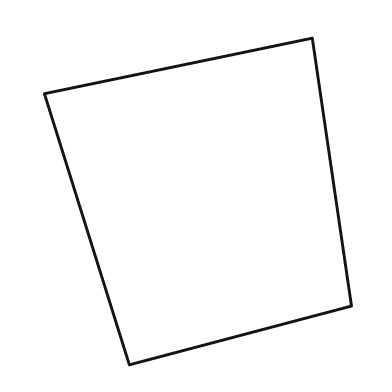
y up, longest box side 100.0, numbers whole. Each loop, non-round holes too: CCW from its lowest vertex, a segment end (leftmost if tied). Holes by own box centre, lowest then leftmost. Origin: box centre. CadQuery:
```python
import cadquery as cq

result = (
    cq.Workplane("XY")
    .moveTo(-21.0, -50.0)
    .lineTo(47.0, -32.0)
    .lineTo(35.0, 50.0)
    .lineTo(-47.0, 33.0)
    .close()
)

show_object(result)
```